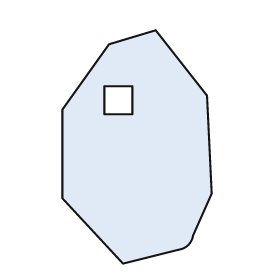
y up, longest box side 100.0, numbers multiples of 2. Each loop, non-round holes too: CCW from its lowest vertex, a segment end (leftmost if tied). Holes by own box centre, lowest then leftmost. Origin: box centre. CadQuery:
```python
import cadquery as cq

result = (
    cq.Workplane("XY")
    .moveTo(-6.0, -50.0)
    .lineTo(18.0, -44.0)
    .threePointArc((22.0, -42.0), (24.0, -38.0))
    .lineTo(32.0, -20.0)
    .lineTo(30.0, 22.0)
    .lineTo(8.0, 50.0)
    .lineTo(-12.0, 44.0)
    .lineTo(-32.0, 16.0)
    .lineTo(-32.0, -22.0)
    .close()
    .moveTo(-14.0, 14.0)
    .lineTo(-2.0, 14.0)
    .lineTo(-2.0, 26.0)
    .lineTo(-14.0, 26.0)
    .close()
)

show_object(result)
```